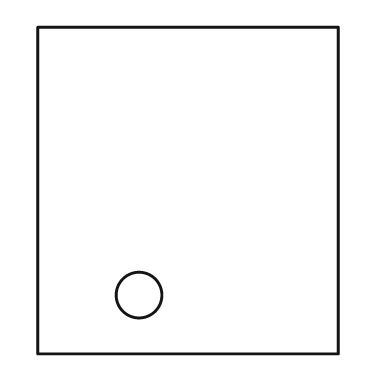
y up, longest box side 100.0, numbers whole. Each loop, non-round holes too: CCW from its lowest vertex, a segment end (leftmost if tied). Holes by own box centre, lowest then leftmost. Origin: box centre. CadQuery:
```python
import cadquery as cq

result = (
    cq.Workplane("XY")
    .moveTo(-46.0, -50.0)
    .lineTo(46.0, -50.0)
    .lineTo(46.0, 50.0)
    .lineTo(-46.0, 50.0)
    .close()
    .moveTo(-15.0, -32.0)
    .circle(7.0)
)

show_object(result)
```